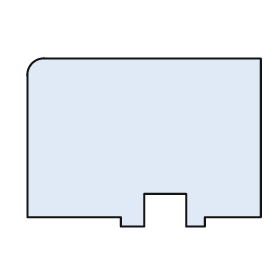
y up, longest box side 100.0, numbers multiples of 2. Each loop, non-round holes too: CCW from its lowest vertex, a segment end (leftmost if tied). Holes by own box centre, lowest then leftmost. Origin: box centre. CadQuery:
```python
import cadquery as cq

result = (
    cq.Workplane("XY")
    .moveTo(-10.0, -36.0)
    .lineTo(0.0, -36.0)
    .lineTo(0.0, -22.0)
    .lineTo(18.0, -22.0)
    .lineTo(18.0, -36.0)
    .lineTo(26.0, -36.0)
    .lineTo(26.0, -32.0)
    .lineTo(50.0, -32.0)
    .lineTo(50.0, 36.0)
    .lineTo(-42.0, 36.0)
    .threePointArc((-48.0, 34.0), (-50.0, 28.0))
    .lineTo(-50.0, -32.0)
    .lineTo(-10.0, -32.0)
    .close()
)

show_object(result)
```